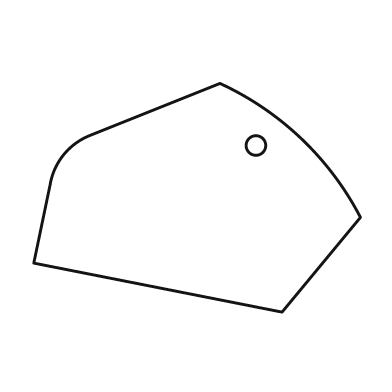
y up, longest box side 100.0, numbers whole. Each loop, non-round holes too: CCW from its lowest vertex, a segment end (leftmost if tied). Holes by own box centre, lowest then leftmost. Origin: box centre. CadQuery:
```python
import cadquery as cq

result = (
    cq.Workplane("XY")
    .moveTo(26.0, -35.0)
    .lineTo(50.0, -6.0)
    .threePointArc((32.0, 18.0), (7.0, 35.0))
    .lineTo(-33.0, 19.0)
    .threePointArc((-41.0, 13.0), (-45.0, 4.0))
    .lineTo(-50.0, -20.0)
    .close()
    .moveTo(18.0, 16.0)
    .circle(3.0)
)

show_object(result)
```